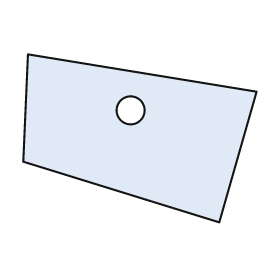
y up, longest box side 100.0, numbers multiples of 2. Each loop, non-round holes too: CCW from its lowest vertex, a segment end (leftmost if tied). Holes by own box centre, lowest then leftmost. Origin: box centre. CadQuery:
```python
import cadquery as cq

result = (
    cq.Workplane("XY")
    .moveTo(34.0, -36.0)
    .lineTo(50.0, 20.0)
    .lineTo(-48.0, 36.0)
    .lineTo(-50.0, -10.0)
    .close()
    .moveTo(-4.0, 12.0)
    .circle(6.0)
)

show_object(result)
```